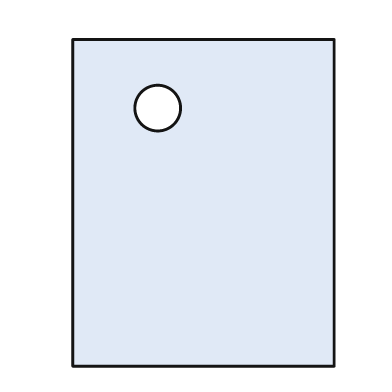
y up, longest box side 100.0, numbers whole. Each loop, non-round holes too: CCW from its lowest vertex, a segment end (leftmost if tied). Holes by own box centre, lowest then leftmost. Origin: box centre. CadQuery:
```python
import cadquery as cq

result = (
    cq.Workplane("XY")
    .moveTo(-40.0, -50.0)
    .lineTo(40.0, -50.0)
    .lineTo(40.0, 50.0)
    .lineTo(-40.0, 50.0)
    .close()
    .moveTo(-14.0, 29.0)
    .circle(7.0)
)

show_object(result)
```